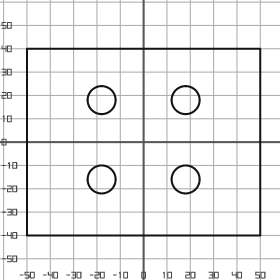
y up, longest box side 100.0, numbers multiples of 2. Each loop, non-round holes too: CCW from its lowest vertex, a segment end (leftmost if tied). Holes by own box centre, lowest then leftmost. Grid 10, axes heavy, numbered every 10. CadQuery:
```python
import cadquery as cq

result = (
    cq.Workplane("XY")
    .moveTo(-50.0, -40.0)
    .lineTo(50.0, -40.0)
    .lineTo(50.0, 40.0)
    .lineTo(-50.0, 40.0)
    .close()
    .moveTo(-18.0, -16.0)
    .circle(6.0)
    .moveTo(18.0, -16.0)
    .circle(6.0)
    .moveTo(-18.0, 18.0)
    .circle(6.0)
    .moveTo(18.0, 18.0)
    .circle(6.0)
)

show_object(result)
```